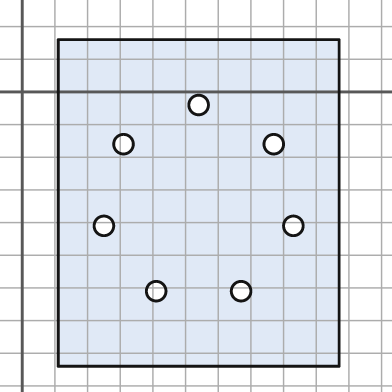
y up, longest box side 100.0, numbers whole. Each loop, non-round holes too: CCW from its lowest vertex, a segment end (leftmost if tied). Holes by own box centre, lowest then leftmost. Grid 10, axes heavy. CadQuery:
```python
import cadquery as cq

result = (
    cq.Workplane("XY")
    .moveTo(11.0, -84.0)
    .lineTo(97.0, -84.0)
    .lineTo(97.0, 16.0)
    .lineTo(11.0, 16.0)
    .close()
    .moveTo(41.0, -61.0)
    .circle(3.0)
    .moveTo(67.0, -61.0)
    .circle(3.0)
    .moveTo(25.0, -41.0)
    .circle(3.0)
    .moveTo(83.0, -41.0)
    .circle(3.0)
    .moveTo(31.0, -16.0)
    .circle(3.0)
    .moveTo(77.0, -16.0)
    .circle(3.0)
    .moveTo(54.0, -4.0)
    .circle(3.0)
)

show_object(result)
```